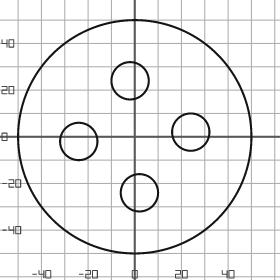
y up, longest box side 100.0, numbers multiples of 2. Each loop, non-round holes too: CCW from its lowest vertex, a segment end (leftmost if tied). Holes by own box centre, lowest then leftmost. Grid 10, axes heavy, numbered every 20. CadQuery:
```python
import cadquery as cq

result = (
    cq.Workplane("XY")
    .moveTo(0.0, 0.0)
    .circle(50.0)
    .moveTo(2.0, -24.0)
    .circle(8.0)
    .moveTo(-24.0, -2.0)
    .circle(8.0)
    .moveTo(24.0, 2.0)
    .circle(8.0)
    .moveTo(-2.0, 24.0)
    .circle(8.0)
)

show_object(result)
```